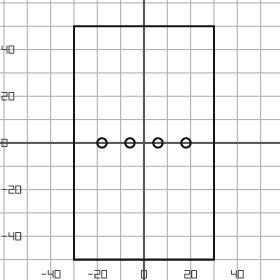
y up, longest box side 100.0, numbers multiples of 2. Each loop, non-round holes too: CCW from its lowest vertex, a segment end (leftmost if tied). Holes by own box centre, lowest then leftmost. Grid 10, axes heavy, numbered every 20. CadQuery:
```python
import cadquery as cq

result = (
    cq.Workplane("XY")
    .moveTo(-30.0, -50.0)
    .lineTo(30.0, -50.0)
    .lineTo(30.0, 50.0)
    .lineTo(-30.0, 50.0)
    .close()
    .moveTo(-18.0, 0.0)
    .circle(2.0)
    .moveTo(-6.0, 0.0)
    .circle(2.0)
    .moveTo(6.0, 0.0)
    .circle(2.0)
    .moveTo(18.0, 0.0)
    .circle(2.0)
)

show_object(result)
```